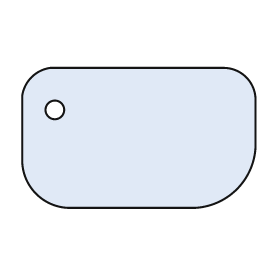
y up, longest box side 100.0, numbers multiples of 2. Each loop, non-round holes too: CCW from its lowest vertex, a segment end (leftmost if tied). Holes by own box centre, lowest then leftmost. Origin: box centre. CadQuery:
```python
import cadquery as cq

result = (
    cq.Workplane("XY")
    .moveTo(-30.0, -30.0)
    .lineTo(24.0, -30.0)
    .threePointArc((42.0, -22.0), (50.0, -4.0))
    .lineTo(50.0, 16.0)
    .threePointArc((46.0, 26.0), (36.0, 30.0))
    .lineTo(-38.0, 30.0)
    .threePointArc((-46.0, 26.0), (-50.0, 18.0))
    .lineTo(-50.0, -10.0)
    .threePointArc((-44.0, -24.0), (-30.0, -30.0))
    .close()
    .moveTo(-36.0, 12.0)
    .circle(4.0)
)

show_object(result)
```